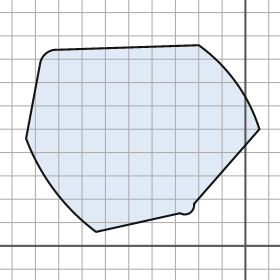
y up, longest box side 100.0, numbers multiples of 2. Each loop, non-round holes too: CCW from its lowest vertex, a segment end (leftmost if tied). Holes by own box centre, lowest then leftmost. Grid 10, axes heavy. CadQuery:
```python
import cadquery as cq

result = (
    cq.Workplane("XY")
    .moveTo(-64.0, 6.0)
    .lineTo(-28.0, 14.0)
    .threePointArc((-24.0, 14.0), (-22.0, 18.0))
    .lineTo(6.0, 50.0)
    .threePointArc((-4.0, 70.0), (-20.0, 86.0))
    .lineTo(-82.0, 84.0)
    .threePointArc((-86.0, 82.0), (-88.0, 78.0))
    .lineTo(-94.0, 46.0)
    .threePointArc((-82.0, 24.0), (-64.0, 6.0))
    .close()
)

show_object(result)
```